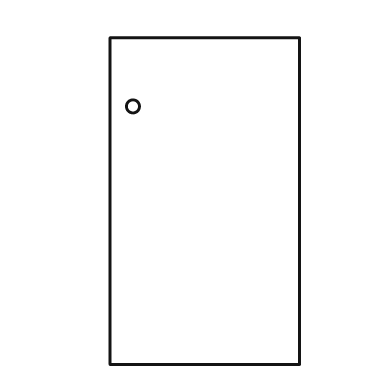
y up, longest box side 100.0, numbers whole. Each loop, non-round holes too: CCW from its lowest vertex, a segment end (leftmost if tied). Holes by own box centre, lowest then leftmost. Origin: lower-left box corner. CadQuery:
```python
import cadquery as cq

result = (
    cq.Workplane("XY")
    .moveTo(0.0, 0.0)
    .lineTo(58.0, 0.0)
    .lineTo(58.0, 100.0)
    .lineTo(0.0, 100.0)
    .close()
    .moveTo(7.0, 79.0)
    .circle(2.0)
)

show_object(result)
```